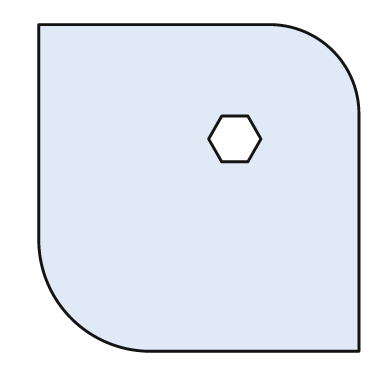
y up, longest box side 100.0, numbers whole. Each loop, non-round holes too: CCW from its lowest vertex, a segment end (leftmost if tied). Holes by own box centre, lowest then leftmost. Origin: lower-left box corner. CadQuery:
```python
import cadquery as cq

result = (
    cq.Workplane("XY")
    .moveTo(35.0, 0.0)
    .lineTo(98.0, 0.0)
    .lineTo(98.0, 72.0)
    .threePointArc((90.0, 92.0), (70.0, 100.0))
    .lineTo(0.0, 100.0)
    .lineTo(0.0, 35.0)
    .threePointArc((10.0, 10.0), (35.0, 0.0))
    .close()
    .moveTo(56.0, 58.0)
    .lineTo(64.0, 58.0)
    .lineTo(68.0, 65.0)
    .lineTo(64.0, 72.0)
    .lineTo(56.0, 72.0)
    .lineTo(52.0, 65.0)
    .close()
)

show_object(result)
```